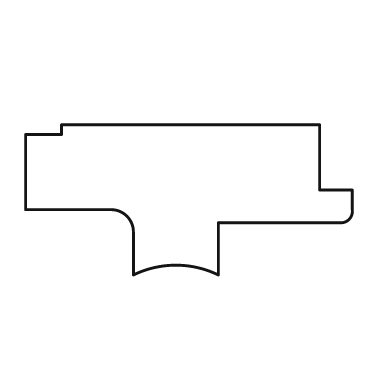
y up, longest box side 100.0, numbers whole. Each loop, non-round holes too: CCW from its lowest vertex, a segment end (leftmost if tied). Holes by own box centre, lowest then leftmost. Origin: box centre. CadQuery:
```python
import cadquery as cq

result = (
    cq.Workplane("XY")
    .moveTo(-17.0, -23.0)
    .threePointArc((-4.0, -20.0), (9.0, -23.0))
    .lineTo(9.0, -7.0)
    .lineTo(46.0, -7.0)
    .threePointArc((49.0, -6.0), (50.0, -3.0))
    .lineTo(50.0, 3.0)
    .lineTo(40.0, 3.0)
    .lineTo(40.0, 23.0)
    .lineTo(-39.0, 23.0)
    .lineTo(-39.0, 20.0)
    .lineTo(-50.0, 20.0)
    .lineTo(-50.0, -3.0)
    .lineTo(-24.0, -3.0)
    .threePointArc((-19.0, -5.0), (-17.0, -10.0))
    .close()
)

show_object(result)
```